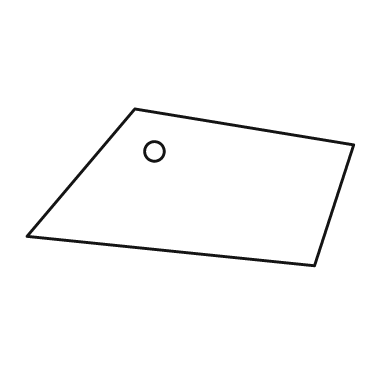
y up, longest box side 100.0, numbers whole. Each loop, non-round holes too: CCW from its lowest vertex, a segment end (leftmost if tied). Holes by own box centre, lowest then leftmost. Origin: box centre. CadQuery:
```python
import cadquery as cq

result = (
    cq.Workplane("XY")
    .moveTo(38.0, -24.0)
    .lineTo(50.0, 13.0)
    .lineTo(-17.0, 24.0)
    .lineTo(-50.0, -15.0)
    .close()
    .moveTo(-11.0, 11.0)
    .circle(3.0)
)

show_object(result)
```